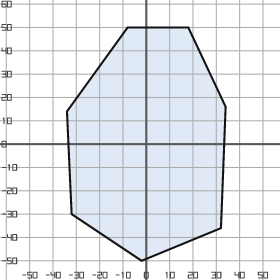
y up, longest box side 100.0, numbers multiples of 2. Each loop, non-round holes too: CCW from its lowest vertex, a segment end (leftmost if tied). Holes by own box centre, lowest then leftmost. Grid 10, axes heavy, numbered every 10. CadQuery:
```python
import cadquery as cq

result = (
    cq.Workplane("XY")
    .moveTo(-2.0, -50.0)
    .lineTo(32.0, -36.0)
    .lineTo(34.0, 16.0)
    .lineTo(18.0, 50.0)
    .lineTo(-8.0, 50.0)
    .lineTo(-34.0, 14.0)
    .lineTo(-32.0, -30.0)
    .close()
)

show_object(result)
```